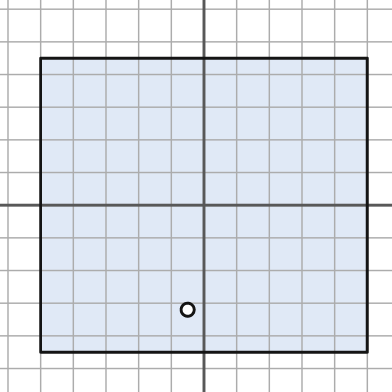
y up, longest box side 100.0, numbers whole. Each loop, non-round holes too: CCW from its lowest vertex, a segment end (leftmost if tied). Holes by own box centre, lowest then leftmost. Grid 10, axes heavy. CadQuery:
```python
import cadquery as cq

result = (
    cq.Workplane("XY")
    .moveTo(-50.0, -45.0)
    .lineTo(50.0, -45.0)
    .lineTo(50.0, 45.0)
    .lineTo(-50.0, 45.0)
    .close()
    .moveTo(-5.0, -32.0)
    .circle(2.0)
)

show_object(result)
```